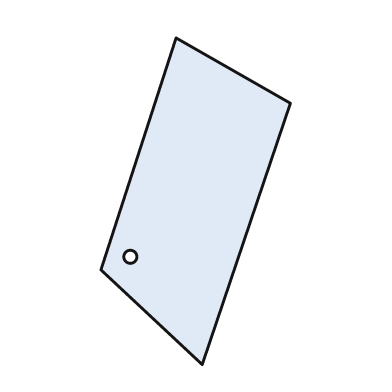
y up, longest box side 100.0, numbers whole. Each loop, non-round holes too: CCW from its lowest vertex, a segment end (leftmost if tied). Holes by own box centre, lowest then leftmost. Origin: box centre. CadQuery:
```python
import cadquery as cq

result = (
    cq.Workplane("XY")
    .moveTo(2.0, -50.0)
    .lineTo(29.0, 30.0)
    .lineTo(-6.0, 50.0)
    .lineTo(-29.0, -21.0)
    .close()
    .moveTo(-20.0, -17.0)
    .circle(2.0)
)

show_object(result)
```